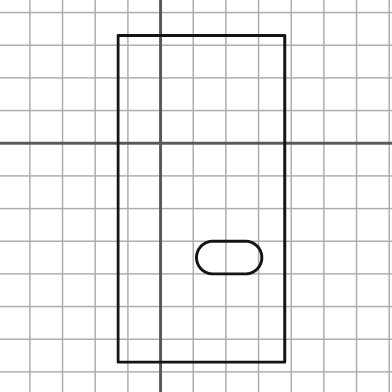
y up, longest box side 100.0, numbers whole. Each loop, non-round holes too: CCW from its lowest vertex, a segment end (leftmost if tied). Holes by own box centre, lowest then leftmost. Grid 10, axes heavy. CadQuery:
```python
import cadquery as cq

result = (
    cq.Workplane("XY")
    .moveTo(-13.0, -67.0)
    .lineTo(38.0, -67.0)
    .lineTo(38.0, 33.0)
    .lineTo(-13.0, 33.0)
    .close()
    .moveTo(16.0, -40.0)
    .lineTo(26.0, -40.0)
    .threePointArc((31.0, -35.0), (26.0, -30.0))
    .lineTo(16.0, -30.0)
    .threePointArc((11.0, -35.0), (16.0, -40.0))
    .close()
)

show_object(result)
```